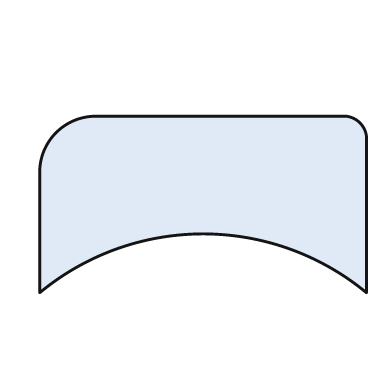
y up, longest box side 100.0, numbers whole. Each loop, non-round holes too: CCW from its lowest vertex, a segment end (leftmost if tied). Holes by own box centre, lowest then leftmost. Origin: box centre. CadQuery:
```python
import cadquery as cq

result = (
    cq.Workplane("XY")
    .moveTo(-50.0, -27.0)
    .threePointArc((0.0, -9.0), (50.0, -27.0))
    .lineTo(50.0, 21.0)
    .threePointArc((48.0, 25.0), (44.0, 27.0))
    .lineTo(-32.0, 27.0)
    .threePointArc((-45.0, 22.0), (-50.0, 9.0))
    .close()
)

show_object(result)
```